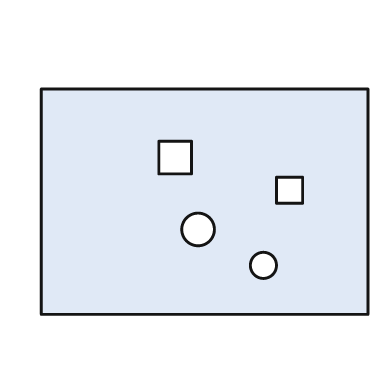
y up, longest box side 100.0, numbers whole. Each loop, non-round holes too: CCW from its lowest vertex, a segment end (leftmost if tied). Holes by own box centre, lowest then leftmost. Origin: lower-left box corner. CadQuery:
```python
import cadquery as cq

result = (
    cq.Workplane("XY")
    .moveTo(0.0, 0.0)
    .lineTo(100.0, 0.0)
    .lineTo(100.0, 69.0)
    .lineTo(0.0, 69.0)
    .close()
    .moveTo(68.0, 15.0)
    .circle(4.0)
    .moveTo(48.0, 26.0)
    .circle(5.0)
    .moveTo(72.0, 34.0)
    .lineTo(80.0, 34.0)
    .lineTo(80.0, 42.0)
    .lineTo(72.0, 42.0)
    .close()
    .moveTo(36.0, 43.0)
    .lineTo(46.0, 43.0)
    .lineTo(46.0, 53.0)
    .lineTo(36.0, 53.0)
    .close()
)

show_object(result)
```